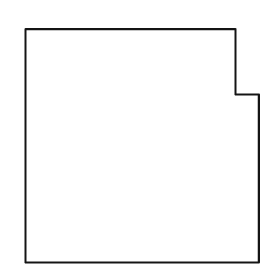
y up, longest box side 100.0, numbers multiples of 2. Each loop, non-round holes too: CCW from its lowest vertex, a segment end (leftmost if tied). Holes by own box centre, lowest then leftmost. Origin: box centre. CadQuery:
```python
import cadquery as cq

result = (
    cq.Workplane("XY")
    .moveTo(-50.0, -50.0)
    .lineTo(50.0, -50.0)
    .lineTo(50.0, 22.0)
    .lineTo(40.0, 22.0)
    .lineTo(40.0, 50.0)
    .lineTo(-50.0, 50.0)
    .close()
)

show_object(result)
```